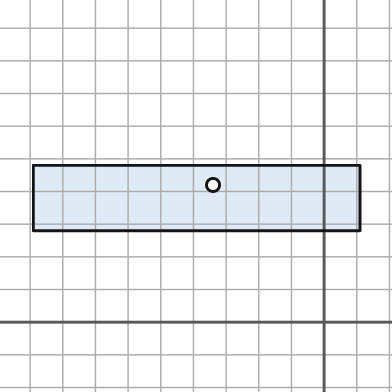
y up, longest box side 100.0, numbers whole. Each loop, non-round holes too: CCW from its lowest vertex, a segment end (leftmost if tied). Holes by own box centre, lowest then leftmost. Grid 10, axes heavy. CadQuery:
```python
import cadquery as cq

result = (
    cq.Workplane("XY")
    .moveTo(-89.0, 28.0)
    .lineTo(11.0, 28.0)
    .lineTo(11.0, 48.0)
    .lineTo(-89.0, 48.0)
    .close()
    .moveTo(-34.0, 42.0)
    .circle(2.0)
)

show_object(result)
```